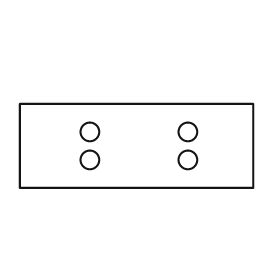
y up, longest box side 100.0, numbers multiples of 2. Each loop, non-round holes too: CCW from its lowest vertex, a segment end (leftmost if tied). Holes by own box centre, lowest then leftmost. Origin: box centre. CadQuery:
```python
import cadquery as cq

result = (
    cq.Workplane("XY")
    .moveTo(-50.0, -18.0)
    .lineTo(50.0, -18.0)
    .lineTo(50.0, 18.0)
    .lineTo(-50.0, 18.0)
    .close()
    .moveTo(-20.0, -6.0)
    .circle(4.0)
    .moveTo(22.0, -6.0)
    .circle(4.0)
    .moveTo(-20.0, 6.0)
    .circle(4.0)
    .moveTo(22.0, 6.0)
    .circle(4.0)
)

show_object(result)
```